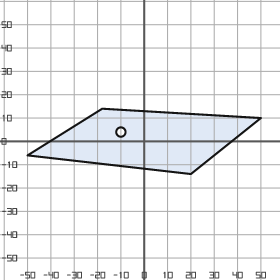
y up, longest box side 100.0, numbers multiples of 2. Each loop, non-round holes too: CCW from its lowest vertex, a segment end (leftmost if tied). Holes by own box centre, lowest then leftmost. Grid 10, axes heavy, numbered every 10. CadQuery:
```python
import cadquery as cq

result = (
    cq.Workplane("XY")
    .moveTo(20.0, -14.0)
    .lineTo(50.0, 10.0)
    .lineTo(-18.0, 14.0)
    .lineTo(-50.0, -6.0)
    .close()
    .moveTo(-10.0, 4.0)
    .circle(2.0)
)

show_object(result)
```